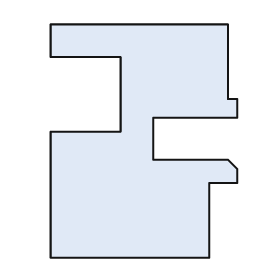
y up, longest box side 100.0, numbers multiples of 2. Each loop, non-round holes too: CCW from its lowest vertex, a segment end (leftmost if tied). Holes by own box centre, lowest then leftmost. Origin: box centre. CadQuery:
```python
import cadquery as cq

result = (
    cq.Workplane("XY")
    .moveTo(-40.0, -50.0)
    .lineTo(28.0, -50.0)
    .lineTo(28.0, -18.0)
    .lineTo(40.0, -18.0)
    .lineTo(40.0, -12.0)
    .lineTo(36.0, -8.0)
    .lineTo(4.0, -8.0)
    .lineTo(4.0, 10.0)
    .lineTo(40.0, 10.0)
    .lineTo(40.0, 18.0)
    .lineTo(36.0, 18.0)
    .lineTo(36.0, 50.0)
    .lineTo(-40.0, 50.0)
    .lineTo(-40.0, 36.0)
    .lineTo(-10.0, 36.0)
    .lineTo(-10.0, 4.0)
    .lineTo(-40.0, 4.0)
    .close()
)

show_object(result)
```